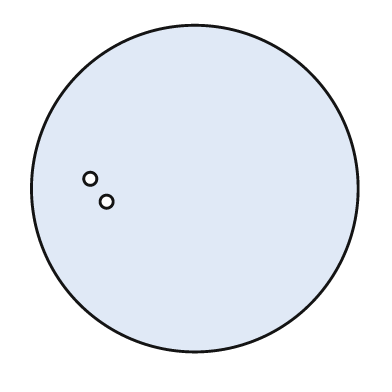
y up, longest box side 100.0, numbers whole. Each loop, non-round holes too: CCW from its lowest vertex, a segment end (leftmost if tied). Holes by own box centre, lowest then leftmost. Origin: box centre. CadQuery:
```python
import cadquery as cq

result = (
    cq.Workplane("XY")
    .moveTo(0.0, 0.0)
    .circle(50.0)
    .moveTo(-27.0, -4.0)
    .circle(2.0)
    .moveTo(-32.0, 3.0)
    .circle(2.0)
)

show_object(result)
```